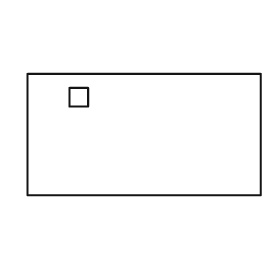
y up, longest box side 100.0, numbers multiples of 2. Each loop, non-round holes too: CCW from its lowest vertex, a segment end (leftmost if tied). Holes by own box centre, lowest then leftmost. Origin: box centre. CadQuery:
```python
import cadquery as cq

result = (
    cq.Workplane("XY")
    .moveTo(-50.0, -26.0)
    .lineTo(50.0, -26.0)
    .lineTo(50.0, 26.0)
    .lineTo(-50.0, 26.0)
    .close()
    .moveTo(-32.0, 12.0)
    .lineTo(-24.0, 12.0)
    .lineTo(-24.0, 20.0)
    .lineTo(-32.0, 20.0)
    .close()
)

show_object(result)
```